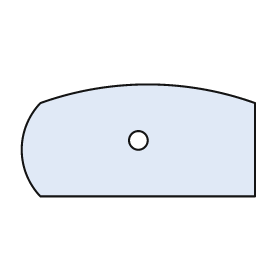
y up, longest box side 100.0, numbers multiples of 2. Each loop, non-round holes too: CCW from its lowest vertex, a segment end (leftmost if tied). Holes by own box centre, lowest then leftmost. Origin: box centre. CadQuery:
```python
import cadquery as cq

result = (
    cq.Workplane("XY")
    .moveTo(-42.0, -24.0)
    .lineTo(50.0, -24.0)
    .lineTo(50.0, 16.0)
    .threePointArc((4.0, 24.0), (-42.0, 16.0))
    .threePointArc((-50.0, -4.0), (-42.0, -24.0))
    .close()
    .moveTo(0.0, 0.0)
    .circle(4.0)
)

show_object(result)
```